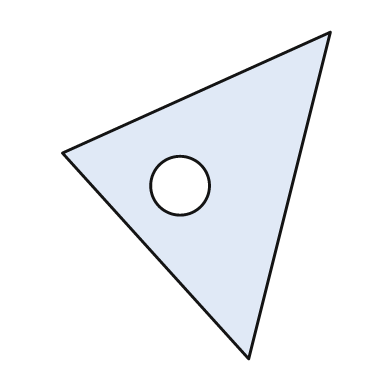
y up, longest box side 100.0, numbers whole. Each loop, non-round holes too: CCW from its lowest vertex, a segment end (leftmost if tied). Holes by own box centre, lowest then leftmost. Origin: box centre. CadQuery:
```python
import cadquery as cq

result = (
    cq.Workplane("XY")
    .moveTo(16.0, -50.0)
    .lineTo(41.0, 50.0)
    .lineTo(-41.0, 13.0)
    .close()
    .moveTo(-5.0, 3.0)
    .circle(9.0)
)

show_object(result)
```